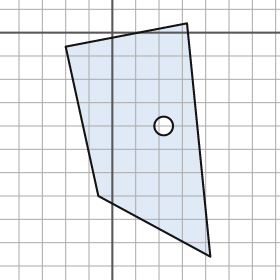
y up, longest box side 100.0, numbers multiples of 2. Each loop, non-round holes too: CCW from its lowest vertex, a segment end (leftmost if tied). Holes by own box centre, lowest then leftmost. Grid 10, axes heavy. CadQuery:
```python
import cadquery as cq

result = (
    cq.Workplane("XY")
    .moveTo(42.0, -96.0)
    .lineTo(32.0, 4.0)
    .lineTo(-20.0, -6.0)
    .lineTo(-6.0, -70.0)
    .close()
    .moveTo(22.0, -40.0)
    .circle(4.0)
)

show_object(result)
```